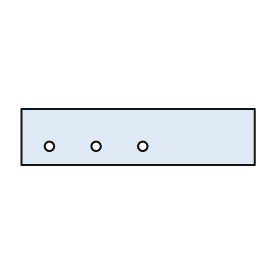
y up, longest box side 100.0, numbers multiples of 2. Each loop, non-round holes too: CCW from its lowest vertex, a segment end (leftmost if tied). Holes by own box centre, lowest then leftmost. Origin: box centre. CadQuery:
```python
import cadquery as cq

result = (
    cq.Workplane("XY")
    .moveTo(-50.0, -12.0)
    .lineTo(50.0, -12.0)
    .lineTo(50.0, 12.0)
    .lineTo(-50.0, 12.0)
    .close()
    .moveTo(-38.0, -4.0)
    .circle(2.0)
    .moveTo(-18.0, -4.0)
    .circle(2.0)
    .moveTo(2.0, -4.0)
    .circle(2.0)
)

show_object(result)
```